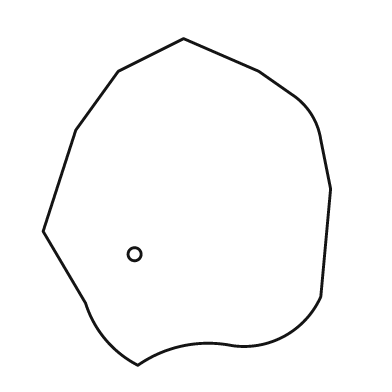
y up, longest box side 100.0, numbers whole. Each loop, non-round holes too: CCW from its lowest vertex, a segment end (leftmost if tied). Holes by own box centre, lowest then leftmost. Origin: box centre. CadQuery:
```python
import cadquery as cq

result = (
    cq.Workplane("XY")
    .moveTo(-15.0, -50.0)
    .threePointArc((-1.0, -44.0), (14.0, -44.0))
    .threePointArc((30.0, -41.0), (41.0, -29.0))
    .lineTo(44.0, 4.0)
    .lineTo(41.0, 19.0)
    .threePointArc((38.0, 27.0), (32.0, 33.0))
    .lineTo(22.0, 40.0)
    .lineTo(-1.0, 50.0)
    .lineTo(-21.0, 40.0)
    .lineTo(-34.0, 22.0)
    .lineTo(-44.0, -9.0)
    .lineTo(-31.0, -31.0)
    .threePointArc((-25.0, -42.0), (-15.0, -50.0))
    .close()
    .moveTo(-16.0, -16.0)
    .circle(2.0)
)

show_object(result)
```